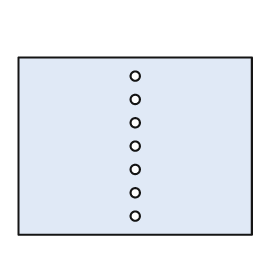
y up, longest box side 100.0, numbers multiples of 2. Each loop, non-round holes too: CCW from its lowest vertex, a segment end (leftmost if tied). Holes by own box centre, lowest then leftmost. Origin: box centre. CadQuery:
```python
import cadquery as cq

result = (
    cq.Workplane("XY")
    .moveTo(-50.0, -38.0)
    .lineTo(50.0, -38.0)
    .lineTo(50.0, 38.0)
    .lineTo(-50.0, 38.0)
    .close()
    .moveTo(0.0, -30.0)
    .circle(2.0)
    .moveTo(0.0, -20.0)
    .circle(2.0)
    .moveTo(0.0, -10.0)
    .circle(2.0)
    .moveTo(0.0, 0.0)
    .circle(2.0)
    .moveTo(0.0, 10.0)
    .circle(2.0)
    .moveTo(0.0, 20.0)
    .circle(2.0)
    .moveTo(0.0, 30.0)
    .circle(2.0)
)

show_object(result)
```